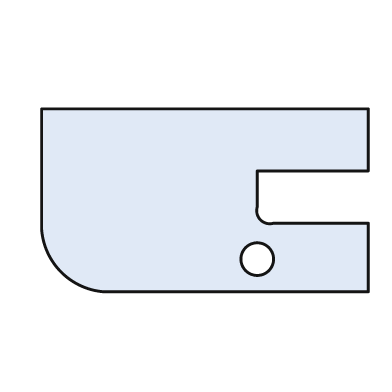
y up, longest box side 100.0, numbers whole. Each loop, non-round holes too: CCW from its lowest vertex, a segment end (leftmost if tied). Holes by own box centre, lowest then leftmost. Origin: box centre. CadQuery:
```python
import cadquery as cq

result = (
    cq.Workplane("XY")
    .moveTo(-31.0, -28.0)
    .lineTo(50.0, -28.0)
    .lineTo(50.0, -7.0)
    .lineTo(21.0, -7.0)
    .threePointArc((17.0, -6.0), (16.0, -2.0))
    .lineTo(16.0, 9.0)
    .lineTo(50.0, 9.0)
    .lineTo(50.0, 28.0)
    .lineTo(-50.0, 28.0)
    .lineTo(-50.0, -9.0)
    .threePointArc((-44.0, -22.0), (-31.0, -28.0))
    .close()
    .moveTo(16.0, -18.0)
    .circle(5.0)
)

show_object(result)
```